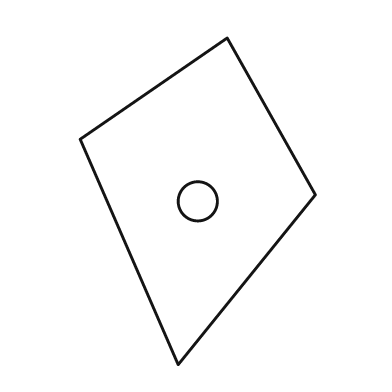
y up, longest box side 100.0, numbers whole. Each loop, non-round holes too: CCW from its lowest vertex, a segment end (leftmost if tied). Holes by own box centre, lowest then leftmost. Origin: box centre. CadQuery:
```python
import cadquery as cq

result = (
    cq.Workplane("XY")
    .moveTo(-6.0, -50.0)
    .lineTo(36.0, 2.0)
    .lineTo(9.0, 50.0)
    .lineTo(-36.0, 19.0)
    .close()
    .moveTo(0.0, 0.0)
    .circle(6.0)
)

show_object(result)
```